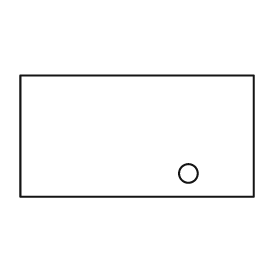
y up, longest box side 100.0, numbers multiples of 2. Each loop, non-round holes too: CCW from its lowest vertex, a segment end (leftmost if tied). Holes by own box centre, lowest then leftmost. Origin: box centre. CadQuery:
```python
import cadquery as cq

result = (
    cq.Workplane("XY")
    .moveTo(-50.0, -26.0)
    .lineTo(50.0, -26.0)
    .lineTo(50.0, 26.0)
    .lineTo(-50.0, 26.0)
    .close()
    .moveTo(22.0, -16.0)
    .circle(4.0)
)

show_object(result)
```